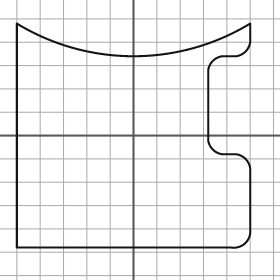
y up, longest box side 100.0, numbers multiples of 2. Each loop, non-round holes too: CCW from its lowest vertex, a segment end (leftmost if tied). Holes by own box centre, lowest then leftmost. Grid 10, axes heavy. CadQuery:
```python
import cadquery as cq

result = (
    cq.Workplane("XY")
    .moveTo(-50.0, -48.0)
    .lineTo(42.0, -48.0)
    .threePointArc((48.0, -46.0), (50.0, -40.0))
    .lineTo(50.0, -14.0)
    .threePointArc((48.0, -10.0), (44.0, -8.0))
    .lineTo(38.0, -8.0)
    .threePointArc((34.0, -6.0), (32.0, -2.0))
    .lineTo(32.0, 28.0)
    .threePointArc((34.0, 32.0), (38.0, 34.0))
    .lineTo(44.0, 34.0)
    .threePointArc((48.0, 36.0), (50.0, 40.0))
    .lineTo(50.0, 48.0)
    .threePointArc((0.0, 34.0), (-50.0, 48.0))
    .close()
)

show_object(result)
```